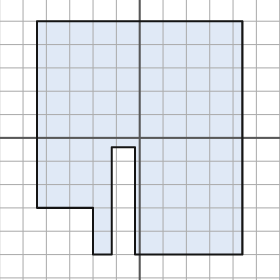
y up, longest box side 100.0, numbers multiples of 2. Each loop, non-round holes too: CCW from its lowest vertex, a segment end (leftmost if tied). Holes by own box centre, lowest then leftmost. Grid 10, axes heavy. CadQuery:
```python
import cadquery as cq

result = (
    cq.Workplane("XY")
    .moveTo(-20.0, -50.0)
    .lineTo(-12.0, -50.0)
    .lineTo(-12.0, -4.0)
    .lineTo(-2.0, -4.0)
    .lineTo(-2.0, -50.0)
    .lineTo(44.0, -50.0)
    .lineTo(44.0, 50.0)
    .lineTo(-44.0, 50.0)
    .lineTo(-44.0, -30.0)
    .lineTo(-20.0, -30.0)
    .close()
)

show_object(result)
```